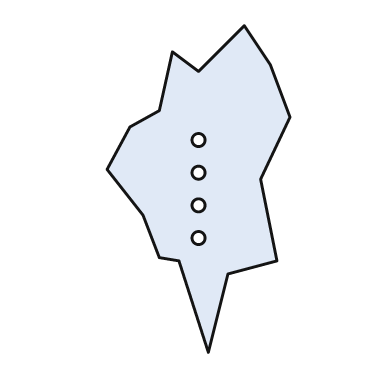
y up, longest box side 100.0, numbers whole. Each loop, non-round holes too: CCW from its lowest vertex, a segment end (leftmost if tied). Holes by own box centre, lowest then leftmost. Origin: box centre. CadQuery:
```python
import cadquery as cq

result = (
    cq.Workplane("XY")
    .moveTo(3.0, -50.0)
    .lineTo(9.0, -26.0)
    .lineTo(24.0, -22.0)
    .lineTo(19.0, 3.0)
    .lineTo(28.0, 22.0)
    .lineTo(22.0, 38.0)
    .lineTo(14.0, 50.0)
    .lineTo(0.0, 36.0)
    .lineTo(-8.0, 42.0)
    .lineTo(-12.0, 24.0)
    .lineTo(-21.0, 19.0)
    .lineTo(-28.0, 6.0)
    .lineTo(-17.0, -8.0)
    .lineTo(-12.0, -21.0)
    .lineTo(-6.0, -22.0)
    .close()
    .moveTo(0.0, -15.0)
    .circle(2.0)
    .moveTo(0.0, -5.0)
    .circle(2.0)
    .moveTo(0.0, 5.0)
    .circle(2.0)
    .moveTo(0.0, 15.0)
    .circle(2.0)
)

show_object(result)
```